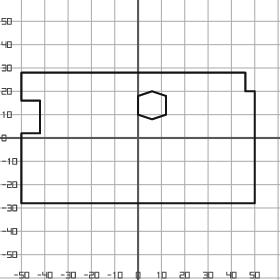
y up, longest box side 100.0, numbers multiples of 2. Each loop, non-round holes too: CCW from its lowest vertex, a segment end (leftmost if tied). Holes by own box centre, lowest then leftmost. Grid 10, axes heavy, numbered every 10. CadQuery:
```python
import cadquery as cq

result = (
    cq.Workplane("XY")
    .moveTo(-50.0, -28.0)
    .lineTo(50.0, -28.0)
    .lineTo(50.0, 20.0)
    .lineTo(46.0, 20.0)
    .lineTo(46.0, 28.0)
    .lineTo(-50.0, 28.0)
    .lineTo(-50.0, 16.0)
    .lineTo(-42.0, 16.0)
    .lineTo(-42.0, 2.0)
    .lineTo(-50.0, 2.0)
    .close()
    .moveTo(6.0, 8.0)
    .lineTo(12.0, 10.0)
    .lineTo(12.0, 18.0)
    .lineTo(6.0, 20.0)
    .lineTo(0.0, 18.0)
    .lineTo(0.0, 10.0)
    .close()
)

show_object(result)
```